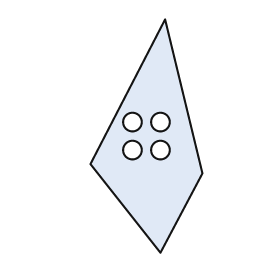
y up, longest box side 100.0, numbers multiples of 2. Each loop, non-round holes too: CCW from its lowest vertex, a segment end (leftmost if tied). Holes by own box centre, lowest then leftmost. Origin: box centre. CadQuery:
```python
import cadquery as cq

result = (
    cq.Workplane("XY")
    .moveTo(6.0, -50.0)
    .lineTo(24.0, -16.0)
    .lineTo(8.0, 50.0)
    .lineTo(-24.0, -12.0)
    .close()
    .moveTo(-6.0, -6.0)
    .circle(4.0)
    .moveTo(6.0, -6.0)
    .circle(4.0)
    .moveTo(-6.0, 6.0)
    .circle(4.0)
    .moveTo(6.0, 6.0)
    .circle(4.0)
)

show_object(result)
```